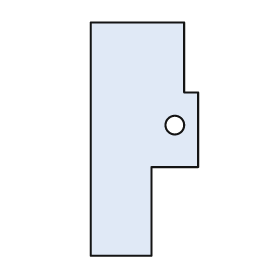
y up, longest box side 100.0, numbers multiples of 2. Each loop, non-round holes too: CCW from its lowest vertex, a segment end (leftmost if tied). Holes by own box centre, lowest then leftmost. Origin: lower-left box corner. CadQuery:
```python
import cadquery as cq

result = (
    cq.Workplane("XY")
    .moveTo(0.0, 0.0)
    .lineTo(26.0, 0.0)
    .lineTo(26.0, 38.0)
    .lineTo(46.0, 38.0)
    .lineTo(46.0, 70.0)
    .lineTo(40.0, 70.0)
    .lineTo(40.0, 100.0)
    .lineTo(0.0, 100.0)
    .close()
    .moveTo(36.0, 56.0)
    .circle(4.0)
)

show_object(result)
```